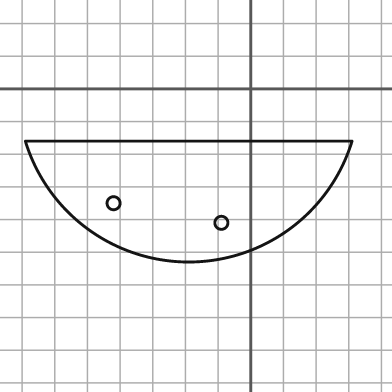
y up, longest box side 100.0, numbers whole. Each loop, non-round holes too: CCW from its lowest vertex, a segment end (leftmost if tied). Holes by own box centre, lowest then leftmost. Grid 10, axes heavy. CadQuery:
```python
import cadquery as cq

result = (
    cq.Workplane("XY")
    .moveTo(-69.0, -16.0)
    .threePointArc((-19.0, -53.0), (31.0, -16.0))
    .close()
    .moveTo(-9.0, -41.0)
    .circle(2.0)
    .moveTo(-42.0, -35.0)
    .circle(2.0)
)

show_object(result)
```